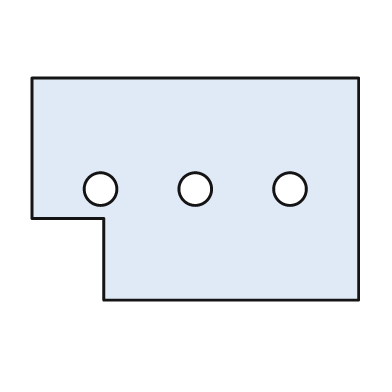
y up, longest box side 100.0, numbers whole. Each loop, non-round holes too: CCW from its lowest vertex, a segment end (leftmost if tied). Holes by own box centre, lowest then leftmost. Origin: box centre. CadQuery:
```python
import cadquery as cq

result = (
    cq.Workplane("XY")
    .moveTo(-28.0, -34.0)
    .lineTo(50.0, -34.0)
    .lineTo(50.0, 34.0)
    .lineTo(-50.0, 34.0)
    .lineTo(-50.0, -9.0)
    .lineTo(-28.0, -9.0)
    .close()
    .moveTo(-29.0, 0.0)
    .circle(5.0)
    .moveTo(0.0, 0.0)
    .circle(5.0)
    .moveTo(29.0, 0.0)
    .circle(5.0)
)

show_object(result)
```